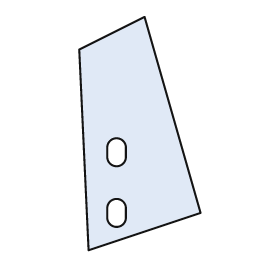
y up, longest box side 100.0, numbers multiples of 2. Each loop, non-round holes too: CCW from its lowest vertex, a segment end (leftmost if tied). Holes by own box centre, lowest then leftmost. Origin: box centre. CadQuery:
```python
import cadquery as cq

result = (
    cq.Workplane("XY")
    .moveTo(-22.0, -50.0)
    .lineTo(26.0, -34.0)
    .lineTo(2.0, 50.0)
    .lineTo(-26.0, 36.0)
    .close()
    .moveTo(-14.0, -36.0)
    .threePointArc((-10.0, -40.0), (-6.0, -36.0))
    .lineTo(-6.0, -32.0)
    .threePointArc((-10.0, -28.0), (-14.0, -32.0))
    .close()
    .moveTo(-14.0, -10.0)
    .threePointArc((-10.0, -14.0), (-6.0, -10.0))
    .lineTo(-6.0, -6.0)
    .threePointArc((-10.0, -2.0), (-14.0, -6.0))
    .close()
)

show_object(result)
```